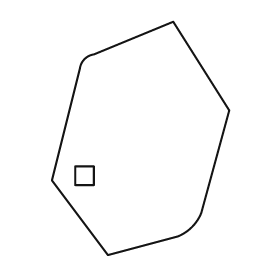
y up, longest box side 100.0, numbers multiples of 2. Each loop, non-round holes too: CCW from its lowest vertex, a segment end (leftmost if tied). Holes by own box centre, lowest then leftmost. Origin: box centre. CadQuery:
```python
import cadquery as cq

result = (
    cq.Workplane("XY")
    .moveTo(-14.0, -50.0)
    .lineTo(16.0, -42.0)
    .threePointArc((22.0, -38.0), (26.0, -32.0))
    .lineTo(38.0, 12.0)
    .lineTo(14.0, 50.0)
    .lineTo(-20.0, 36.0)
    .threePointArc((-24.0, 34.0), (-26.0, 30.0))
    .lineTo(-38.0, -18.0)
    .close()
    .moveTo(-28.0, -20.0)
    .lineTo(-20.0, -20.0)
    .lineTo(-20.0, -12.0)
    .lineTo(-28.0, -12.0)
    .close()
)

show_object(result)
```